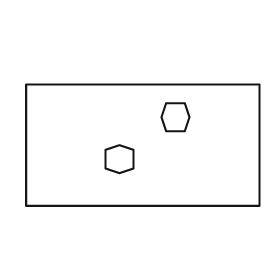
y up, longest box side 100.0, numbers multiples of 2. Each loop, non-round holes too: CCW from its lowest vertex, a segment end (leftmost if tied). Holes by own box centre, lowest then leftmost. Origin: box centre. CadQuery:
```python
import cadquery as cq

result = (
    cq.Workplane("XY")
    .moveTo(-50.0, -26.0)
    .lineTo(50.0, -26.0)
    .lineTo(50.0, 26.0)
    .lineTo(-50.0, 26.0)
    .close()
    .moveTo(-10.0, -12.0)
    .lineTo(-4.0, -10.0)
    .lineTo(-4.0, -2.0)
    .lineTo(-10.0, 0.0)
    .lineTo(-16.0, -2.0)
    .lineTo(-16.0, -10.0)
    .close()
    .moveTo(10.0, 6.0)
    .lineTo(18.0, 6.0)
    .lineTo(20.0, 12.0)
    .lineTo(18.0, 18.0)
    .lineTo(10.0, 18.0)
    .lineTo(8.0, 12.0)
    .close()
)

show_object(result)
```